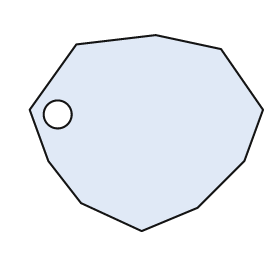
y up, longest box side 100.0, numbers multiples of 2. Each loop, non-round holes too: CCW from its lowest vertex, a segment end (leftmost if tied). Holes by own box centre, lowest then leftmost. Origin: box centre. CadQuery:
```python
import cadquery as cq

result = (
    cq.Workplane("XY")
    .moveTo(-2.0, -42.0)
    .lineTo(22.0, -32.0)
    .lineTo(42.0, -12.0)
    .lineTo(50.0, 10.0)
    .lineTo(32.0, 36.0)
    .lineTo(4.0, 42.0)
    .lineTo(-30.0, 38.0)
    .lineTo(-50.0, 10.0)
    .lineTo(-42.0, -12.0)
    .lineTo(-28.0, -30.0)
    .close()
    .moveTo(-38.0, 8.0)
    .circle(6.0)
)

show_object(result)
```